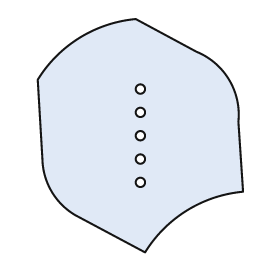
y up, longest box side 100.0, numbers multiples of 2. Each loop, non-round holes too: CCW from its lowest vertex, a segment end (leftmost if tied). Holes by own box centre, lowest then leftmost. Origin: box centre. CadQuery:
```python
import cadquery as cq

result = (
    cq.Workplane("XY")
    .moveTo(2.0, -50.0)
    .threePointArc((20.0, -32.0), (44.0, -24.0))
    .lineTo(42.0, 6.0)
    .threePointArc((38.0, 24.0), (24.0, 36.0))
    .lineTo(-2.0, 50.0)
    .threePointArc((-26.0, 42.0), (-44.0, 24.0))
    .lineTo(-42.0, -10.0)
    .threePointArc((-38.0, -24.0), (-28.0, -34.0))
    .close()
    .moveTo(0.0, -20.0)
    .circle(2.0)
    .moveTo(0.0, -10.0)
    .circle(2.0)
    .moveTo(0.0, 0.0)
    .circle(2.0)
    .moveTo(0.0, 10.0)
    .circle(2.0)
    .moveTo(0.0, 20.0)
    .circle(2.0)
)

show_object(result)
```